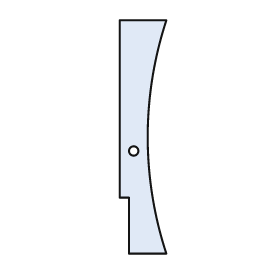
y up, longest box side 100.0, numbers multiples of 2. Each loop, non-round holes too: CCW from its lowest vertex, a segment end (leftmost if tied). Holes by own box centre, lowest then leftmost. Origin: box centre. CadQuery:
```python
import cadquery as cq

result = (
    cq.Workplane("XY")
    .moveTo(-6.0, -50.0)
    .lineTo(10.0, -50.0)
    .threePointArc((2.0, 0.0), (10.0, 50.0))
    .lineTo(-10.0, 50.0)
    .lineTo(-10.0, -26.0)
    .lineTo(-6.0, -26.0)
    .close()
    .moveTo(-4.0, -6.0)
    .circle(2.0)
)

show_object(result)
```